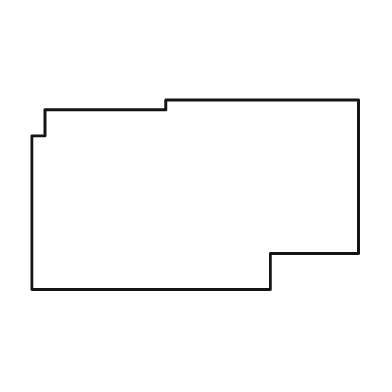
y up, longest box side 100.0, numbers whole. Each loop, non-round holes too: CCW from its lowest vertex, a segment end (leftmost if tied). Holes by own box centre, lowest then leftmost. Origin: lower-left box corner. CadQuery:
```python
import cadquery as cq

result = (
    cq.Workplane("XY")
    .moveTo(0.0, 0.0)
    .lineTo(73.0, 0.0)
    .lineTo(73.0, 11.0)
    .lineTo(100.0, 11.0)
    .lineTo(100.0, 58.0)
    .lineTo(41.0, 58.0)
    .lineTo(41.0, 55.0)
    .lineTo(4.0, 55.0)
    .lineTo(4.0, 47.0)
    .lineTo(0.0, 47.0)
    .close()
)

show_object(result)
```